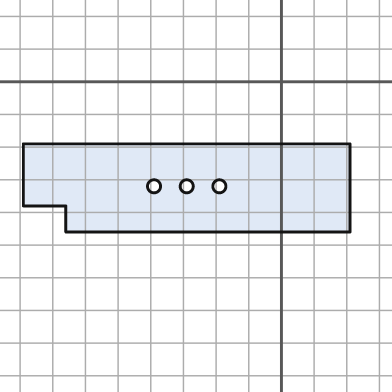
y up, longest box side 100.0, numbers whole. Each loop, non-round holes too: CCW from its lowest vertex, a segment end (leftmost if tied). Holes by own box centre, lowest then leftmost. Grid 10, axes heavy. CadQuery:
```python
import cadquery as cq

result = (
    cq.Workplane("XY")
    .moveTo(-66.0, -46.0)
    .lineTo(21.0, -46.0)
    .lineTo(21.0, -19.0)
    .lineTo(-79.0, -19.0)
    .lineTo(-79.0, -38.0)
    .lineTo(-66.0, -38.0)
    .close()
    .moveTo(-39.0, -32.0)
    .circle(2.0)
    .moveTo(-29.0, -32.0)
    .circle(2.0)
    .moveTo(-19.0, -32.0)
    .circle(2.0)
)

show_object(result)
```